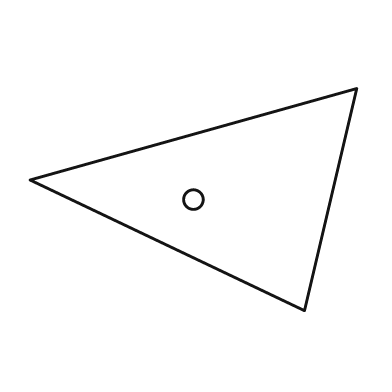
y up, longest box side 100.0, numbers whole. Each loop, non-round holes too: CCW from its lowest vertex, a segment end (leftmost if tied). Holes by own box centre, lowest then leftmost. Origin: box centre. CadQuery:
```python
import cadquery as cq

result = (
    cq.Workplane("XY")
    .moveTo(34.0, -34.0)
    .lineTo(50.0, 34.0)
    .lineTo(-50.0, 6.0)
    .close()
    .moveTo(0.0, 0.0)
    .circle(3.0)
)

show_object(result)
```